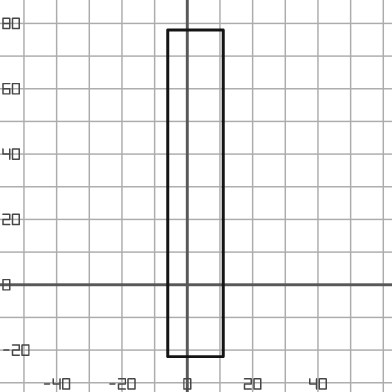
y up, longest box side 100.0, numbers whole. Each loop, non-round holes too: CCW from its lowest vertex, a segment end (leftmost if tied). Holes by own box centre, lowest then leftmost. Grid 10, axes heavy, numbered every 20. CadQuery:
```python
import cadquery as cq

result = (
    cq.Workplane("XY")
    .moveTo(-6.0, -22.0)
    .lineTo(11.0, -22.0)
    .lineTo(11.0, 78.0)
    .lineTo(-6.0, 78.0)
    .close()
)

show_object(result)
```